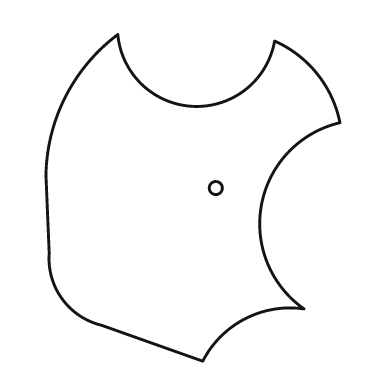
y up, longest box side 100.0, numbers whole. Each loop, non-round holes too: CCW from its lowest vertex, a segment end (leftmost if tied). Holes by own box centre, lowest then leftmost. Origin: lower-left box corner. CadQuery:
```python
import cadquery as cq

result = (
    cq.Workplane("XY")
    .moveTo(48.0, 0.0)
    .threePointArc((61.0, 13.0), (79.0, 16.0))
    .threePointArc((66.0, 48.0), (90.0, 73.0))
    .threePointArc((83.0, 88.0), (70.0, 98.0))
    .threePointArc((45.0, 78.0), (22.0, 100.0))
    .threePointArc((6.0, 81.0), (0.0, 57.0))
    .lineTo(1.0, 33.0)
    .threePointArc((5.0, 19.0), (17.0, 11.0))
    .close()
    .moveTo(52.0, 53.0)
    .circle(2.0)
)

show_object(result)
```